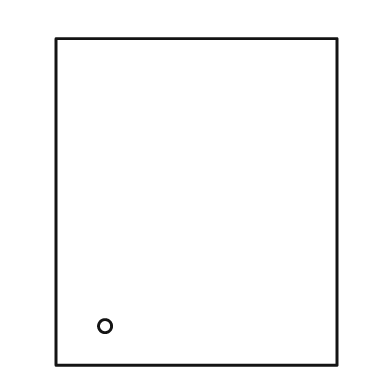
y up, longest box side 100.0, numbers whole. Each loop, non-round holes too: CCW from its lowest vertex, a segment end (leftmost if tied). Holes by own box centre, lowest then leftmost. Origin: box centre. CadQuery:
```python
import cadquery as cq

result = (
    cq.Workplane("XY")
    .moveTo(-43.0, -50.0)
    .lineTo(43.0, -50.0)
    .lineTo(43.0, 50.0)
    .lineTo(-43.0, 50.0)
    .close()
    .moveTo(-28.0, -38.0)
    .circle(2.0)
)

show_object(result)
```